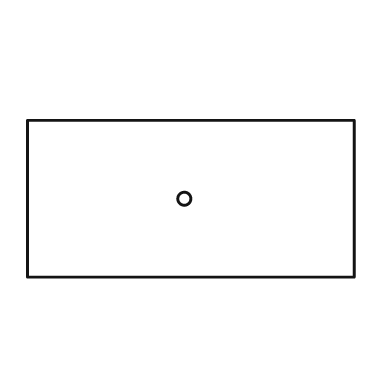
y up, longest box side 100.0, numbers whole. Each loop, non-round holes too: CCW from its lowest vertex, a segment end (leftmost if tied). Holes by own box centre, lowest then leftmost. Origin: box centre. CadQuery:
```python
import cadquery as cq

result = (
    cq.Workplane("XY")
    .moveTo(-50.0, -24.0)
    .lineTo(50.0, -24.0)
    .lineTo(50.0, 24.0)
    .lineTo(-50.0, 24.0)
    .close()
    .moveTo(-2.0, 0.0)
    .circle(2.0)
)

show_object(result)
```